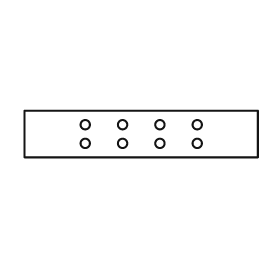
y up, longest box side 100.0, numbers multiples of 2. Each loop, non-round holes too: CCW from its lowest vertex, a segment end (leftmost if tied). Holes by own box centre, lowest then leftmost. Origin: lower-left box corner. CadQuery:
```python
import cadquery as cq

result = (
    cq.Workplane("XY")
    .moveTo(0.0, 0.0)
    .lineTo(100.0, 0.0)
    .lineTo(100.0, 20.0)
    .lineTo(0.0, 20.0)
    .close()
    .moveTo(26.0, 6.0)
    .circle(2.0)
    .moveTo(42.0, 6.0)
    .circle(2.0)
    .moveTo(58.0, 6.0)
    .circle(2.0)
    .moveTo(74.0, 6.0)
    .circle(2.0)
    .moveTo(26.0, 14.0)
    .circle(2.0)
    .moveTo(42.0, 14.0)
    .circle(2.0)
    .moveTo(58.0, 14.0)
    .circle(2.0)
    .moveTo(74.0, 14.0)
    .circle(2.0)
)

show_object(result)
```